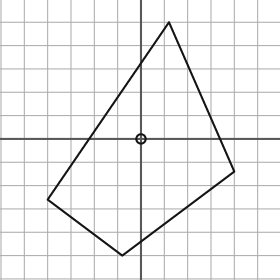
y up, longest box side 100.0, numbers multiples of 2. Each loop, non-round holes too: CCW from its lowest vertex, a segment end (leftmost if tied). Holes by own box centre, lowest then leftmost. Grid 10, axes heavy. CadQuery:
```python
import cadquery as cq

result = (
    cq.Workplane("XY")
    .moveTo(-8.0, -50.0)
    .lineTo(40.0, -14.0)
    .lineTo(12.0, 50.0)
    .lineTo(-40.0, -26.0)
    .close()
    .moveTo(0.0, 0.0)
    .circle(2.0)
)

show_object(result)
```